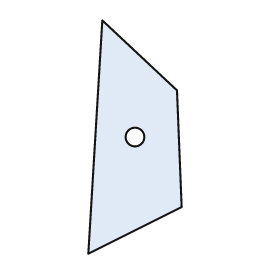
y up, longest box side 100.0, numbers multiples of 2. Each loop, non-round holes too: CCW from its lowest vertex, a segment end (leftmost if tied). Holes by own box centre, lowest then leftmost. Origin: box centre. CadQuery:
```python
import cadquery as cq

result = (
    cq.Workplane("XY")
    .moveTo(-20.0, -50.0)
    .lineTo(20.0, -30.0)
    .lineTo(18.0, 20.0)
    .lineTo(-14.0, 50.0)
    .close()
    .moveTo(0.0, 0.0)
    .circle(4.0)
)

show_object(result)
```